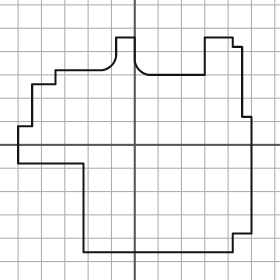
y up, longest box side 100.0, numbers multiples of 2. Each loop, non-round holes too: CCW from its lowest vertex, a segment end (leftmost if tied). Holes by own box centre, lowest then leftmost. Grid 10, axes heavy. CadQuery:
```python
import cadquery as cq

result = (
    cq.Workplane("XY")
    .moveTo(-22.0, -46.0)
    .lineTo(42.0, -46.0)
    .lineTo(42.0, -38.0)
    .lineTo(50.0, -38.0)
    .lineTo(50.0, 12.0)
    .lineTo(46.0, 12.0)
    .lineTo(46.0, 42.0)
    .lineTo(42.0, 42.0)
    .lineTo(42.0, 46.0)
    .lineTo(30.0, 46.0)
    .lineTo(30.0, 30.0)
    .lineTo(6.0, 30.0)
    .threePointArc((2.0, 32.0), (0.0, 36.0))
    .lineTo(0.0, 46.0)
    .lineTo(-8.0, 46.0)
    .lineTo(-8.0, 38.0)
    .threePointArc((-10.0, 34.0), (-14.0, 32.0))
    .lineTo(-34.0, 32.0)
    .lineTo(-34.0, 26.0)
    .lineTo(-44.0, 26.0)
    .lineTo(-44.0, 8.0)
    .lineTo(-50.0, 8.0)
    .lineTo(-50.0, -8.0)
    .lineTo(-22.0, -8.0)
    .close()
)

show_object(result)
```